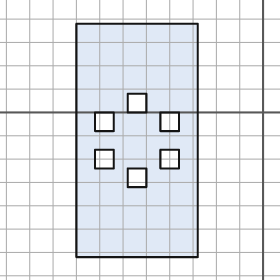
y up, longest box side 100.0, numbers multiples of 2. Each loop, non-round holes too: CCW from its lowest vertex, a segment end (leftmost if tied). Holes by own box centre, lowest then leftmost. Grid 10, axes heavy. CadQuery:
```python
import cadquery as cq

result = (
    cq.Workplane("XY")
    .moveTo(-80.0, -62.0)
    .lineTo(-28.0, -62.0)
    .lineTo(-28.0, 38.0)
    .lineTo(-80.0, 38.0)
    .close()
    .moveTo(-58.0, -32.0)
    .lineTo(-50.0, -32.0)
    .lineTo(-50.0, -24.0)
    .lineTo(-58.0, -24.0)
    .close()
    .moveTo(-72.0, -24.0)
    .lineTo(-64.0, -24.0)
    .lineTo(-64.0, -16.0)
    .lineTo(-72.0, -16.0)
    .close()
    .moveTo(-44.0, -24.0)
    .lineTo(-36.0, -24.0)
    .lineTo(-36.0, -16.0)
    .lineTo(-44.0, -16.0)
    .close()
    .moveTo(-72.0, -8.0)
    .lineTo(-64.0, -8.0)
    .lineTo(-64.0, 0.0)
    .lineTo(-72.0, 0.0)
    .close()
    .moveTo(-44.0, -8.0)
    .lineTo(-36.0, -8.0)
    .lineTo(-36.0, 0.0)
    .lineTo(-44.0, 0.0)
    .close()
    .moveTo(-58.0, 0.0)
    .lineTo(-50.0, 0.0)
    .lineTo(-50.0, 8.0)
    .lineTo(-58.0, 8.0)
    .close()
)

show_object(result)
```